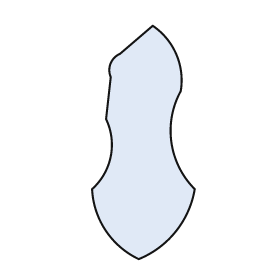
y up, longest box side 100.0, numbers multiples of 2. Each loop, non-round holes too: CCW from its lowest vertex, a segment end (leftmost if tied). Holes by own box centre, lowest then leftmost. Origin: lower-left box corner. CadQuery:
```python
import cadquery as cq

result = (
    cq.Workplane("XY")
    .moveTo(20.0, 0.0)
    .threePointArc((36.0, 12.0), (44.0, 30.0))
    .threePointArc((34.0, 50.0), (38.0, 72.0))
    .threePointArc((36.0, 88.0), (26.0, 100.0))
    .lineTo(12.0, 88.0)
    .threePointArc((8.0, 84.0), (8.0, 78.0))
    .lineTo(6.0, 60.0)
    .threePointArc((8.0, 44.0), (0.0, 30.0))
    .threePointArc((6.0, 12.0), (20.0, 0.0))
    .close()
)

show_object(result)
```